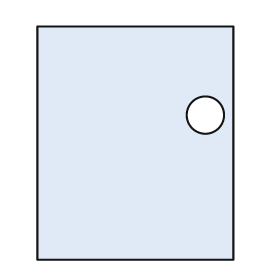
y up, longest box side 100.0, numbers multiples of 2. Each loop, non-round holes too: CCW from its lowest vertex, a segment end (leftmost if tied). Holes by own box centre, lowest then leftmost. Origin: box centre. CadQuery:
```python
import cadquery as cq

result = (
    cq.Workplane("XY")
    .moveTo(-42.0, -50.0)
    .lineTo(42.0, -50.0)
    .lineTo(42.0, 50.0)
    .lineTo(-42.0, 50.0)
    .close()
    .moveTo(30.0, 12.0)
    .circle(8.0)
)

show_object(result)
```